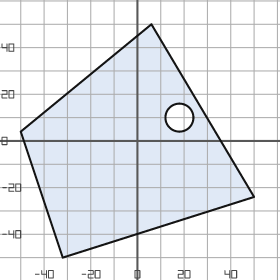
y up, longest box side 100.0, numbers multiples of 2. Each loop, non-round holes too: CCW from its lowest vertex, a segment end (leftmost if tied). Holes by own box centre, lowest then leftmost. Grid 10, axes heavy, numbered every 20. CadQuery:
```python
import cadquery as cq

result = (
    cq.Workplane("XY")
    .moveTo(-32.0, -50.0)
    .lineTo(50.0, -24.0)
    .lineTo(6.0, 50.0)
    .lineTo(-50.0, 4.0)
    .close()
    .moveTo(18.0, 10.0)
    .circle(6.0)
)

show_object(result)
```